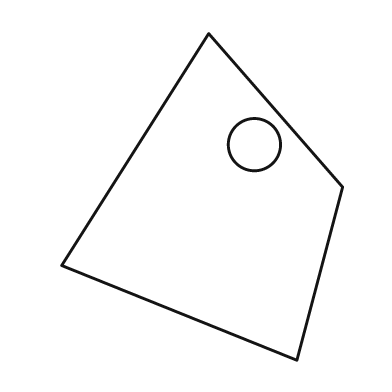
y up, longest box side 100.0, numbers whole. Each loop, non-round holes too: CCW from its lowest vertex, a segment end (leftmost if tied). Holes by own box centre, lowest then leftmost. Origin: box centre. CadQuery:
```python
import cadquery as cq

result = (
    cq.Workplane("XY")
    .moveTo(29.0, -50.0)
    .lineTo(43.0, 3.0)
    .lineTo(2.0, 50.0)
    .lineTo(-43.0, -21.0)
    .close()
    .moveTo(16.0, 16.0)
    .circle(8.0)
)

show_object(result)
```